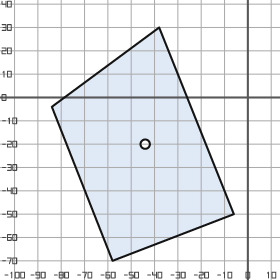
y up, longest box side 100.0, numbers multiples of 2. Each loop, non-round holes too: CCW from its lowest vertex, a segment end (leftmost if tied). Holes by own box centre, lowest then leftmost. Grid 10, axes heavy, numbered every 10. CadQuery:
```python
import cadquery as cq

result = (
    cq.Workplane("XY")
    .moveTo(-58.0, -70.0)
    .lineTo(-6.0, -50.0)
    .lineTo(-38.0, 30.0)
    .lineTo(-84.0, -4.0)
    .close()
    .moveTo(-44.0, -20.0)
    .circle(2.0)
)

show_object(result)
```